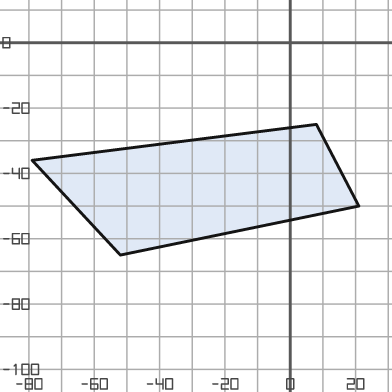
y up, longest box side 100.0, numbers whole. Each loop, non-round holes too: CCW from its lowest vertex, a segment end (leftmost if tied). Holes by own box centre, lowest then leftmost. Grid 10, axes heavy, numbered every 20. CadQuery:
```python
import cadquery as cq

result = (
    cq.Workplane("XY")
    .moveTo(-52.0, -65.0)
    .lineTo(21.0, -50.0)
    .lineTo(8.0, -25.0)
    .lineTo(-79.0, -36.0)
    .close()
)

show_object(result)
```